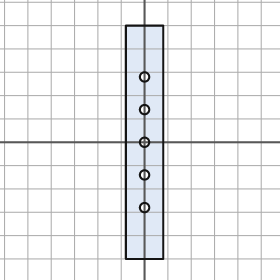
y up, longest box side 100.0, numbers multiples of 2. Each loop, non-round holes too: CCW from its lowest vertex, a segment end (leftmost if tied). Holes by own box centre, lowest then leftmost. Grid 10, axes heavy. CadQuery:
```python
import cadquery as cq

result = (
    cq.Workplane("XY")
    .moveTo(-8.0, -50.0)
    .lineTo(8.0, -50.0)
    .lineTo(8.0, 50.0)
    .lineTo(-8.0, 50.0)
    .close()
    .moveTo(0.0, -28.0)
    .circle(2.0)
    .moveTo(0.0, -14.0)
    .circle(2.0)
    .moveTo(0.0, 0.0)
    .circle(2.0)
    .moveTo(0.0, 14.0)
    .circle(2.0)
    .moveTo(0.0, 28.0)
    .circle(2.0)
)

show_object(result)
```